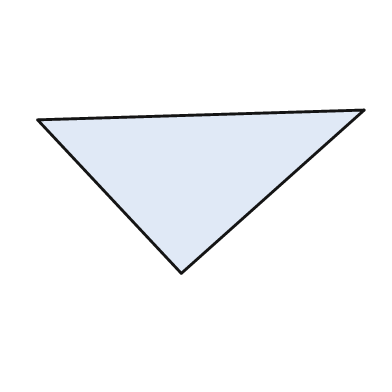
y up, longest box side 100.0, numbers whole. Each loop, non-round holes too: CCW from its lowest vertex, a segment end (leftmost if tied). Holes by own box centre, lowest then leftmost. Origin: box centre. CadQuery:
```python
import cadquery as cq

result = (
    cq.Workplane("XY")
    .moveTo(-6.0, -25.0)
    .lineTo(50.0, 25.0)
    .lineTo(-50.0, 22.0)
    .close()
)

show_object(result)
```